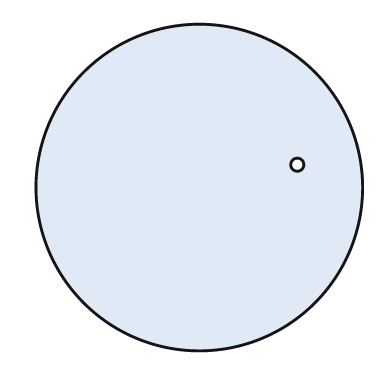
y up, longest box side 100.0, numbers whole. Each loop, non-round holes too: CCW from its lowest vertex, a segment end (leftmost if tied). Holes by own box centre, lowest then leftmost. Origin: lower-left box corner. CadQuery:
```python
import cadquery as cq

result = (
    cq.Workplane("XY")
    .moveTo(50.0, 50.0)
    .circle(50.0)
    .moveTo(80.0, 57.0)
    .circle(2.0)
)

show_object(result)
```